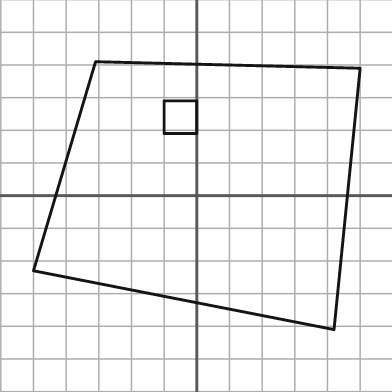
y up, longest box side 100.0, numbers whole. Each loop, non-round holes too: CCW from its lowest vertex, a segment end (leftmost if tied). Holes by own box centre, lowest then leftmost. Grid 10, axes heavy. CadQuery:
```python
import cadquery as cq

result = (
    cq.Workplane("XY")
    .moveTo(42.0, -41.0)
    .lineTo(50.0, 39.0)
    .lineTo(-31.0, 41.0)
    .lineTo(-50.0, -23.0)
    .close()
    .moveTo(-10.0, 19.0)
    .lineTo(0.0, 19.0)
    .lineTo(0.0, 29.0)
    .lineTo(-10.0, 29.0)
    .close()
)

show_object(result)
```